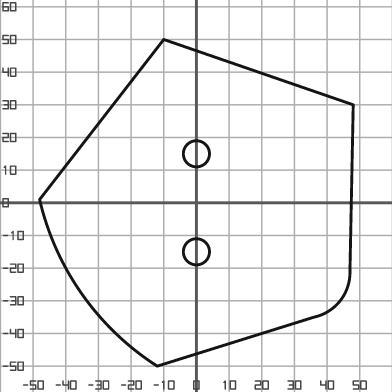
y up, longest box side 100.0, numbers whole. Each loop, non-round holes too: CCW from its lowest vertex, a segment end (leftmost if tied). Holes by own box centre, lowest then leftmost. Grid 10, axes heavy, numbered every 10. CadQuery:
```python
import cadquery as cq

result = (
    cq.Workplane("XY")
    .moveTo(-12.0, -50.0)
    .lineTo(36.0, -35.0)
    .threePointArc((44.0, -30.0), (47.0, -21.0))
    .lineTo(48.0, 30.0)
    .lineTo(-10.0, 50.0)
    .lineTo(-48.0, 1.0)
    .threePointArc((-35.0, -28.0), (-12.0, -50.0))
    .close()
    .moveTo(0.0, -15.0)
    .circle(4.0)
    .moveTo(0.0, 15.0)
    .circle(4.0)
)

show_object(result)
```